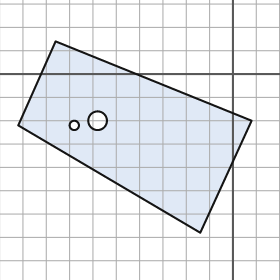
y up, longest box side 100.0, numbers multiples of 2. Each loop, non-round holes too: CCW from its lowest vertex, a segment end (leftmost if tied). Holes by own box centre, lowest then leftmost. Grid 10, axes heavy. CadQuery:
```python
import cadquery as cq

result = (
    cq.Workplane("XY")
    .moveTo(-14.0, -68.0)
    .lineTo(8.0, -20.0)
    .lineTo(-76.0, 14.0)
    .lineTo(-92.0, -22.0)
    .close()
    .moveTo(-68.0, -22.0)
    .circle(2.0)
    .moveTo(-58.0, -20.0)
    .circle(4.0)
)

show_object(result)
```